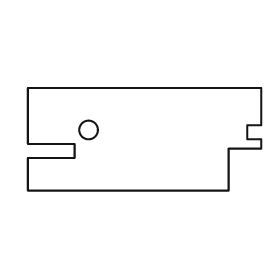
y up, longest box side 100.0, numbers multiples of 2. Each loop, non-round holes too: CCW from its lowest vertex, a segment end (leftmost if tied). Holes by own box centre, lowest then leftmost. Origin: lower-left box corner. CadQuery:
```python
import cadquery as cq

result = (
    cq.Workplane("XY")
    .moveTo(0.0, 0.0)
    .lineTo(86.0, 0.0)
    .lineTo(86.0, 18.0)
    .lineTo(100.0, 18.0)
    .lineTo(100.0, 22.0)
    .lineTo(94.0, 22.0)
    .lineTo(94.0, 28.0)
    .lineTo(100.0, 28.0)
    .lineTo(100.0, 44.0)
    .lineTo(0.0, 44.0)
    .lineTo(0.0, 20.0)
    .lineTo(20.0, 20.0)
    .lineTo(20.0, 14.0)
    .lineTo(0.0, 14.0)
    .close()
    .moveTo(26.0, 26.0)
    .circle(4.0)
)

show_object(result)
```